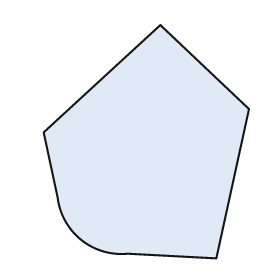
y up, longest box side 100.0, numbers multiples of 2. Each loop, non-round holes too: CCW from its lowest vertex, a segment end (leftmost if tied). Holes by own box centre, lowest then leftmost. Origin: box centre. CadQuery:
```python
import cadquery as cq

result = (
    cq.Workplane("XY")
    .moveTo(30.0, -50.0)
    .lineTo(44.0, 14.0)
    .lineTo(6.0, 50.0)
    .lineTo(-44.0, 4.0)
    .lineTo(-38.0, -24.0)
    .threePointArc((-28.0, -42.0), (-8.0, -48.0))
    .close()
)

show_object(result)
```